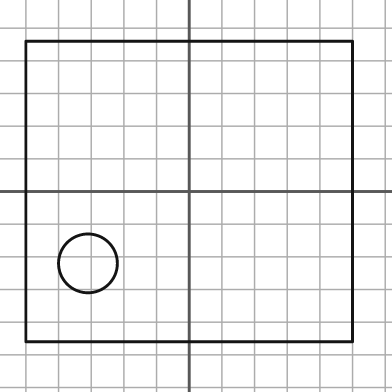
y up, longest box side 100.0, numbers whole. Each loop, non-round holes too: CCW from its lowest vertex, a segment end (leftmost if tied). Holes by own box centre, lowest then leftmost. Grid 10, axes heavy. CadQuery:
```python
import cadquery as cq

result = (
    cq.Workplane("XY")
    .moveTo(-50.0, -46.0)
    .lineTo(50.0, -46.0)
    .lineTo(50.0, 46.0)
    .lineTo(-50.0, 46.0)
    .close()
    .moveTo(-31.0, -22.0)
    .circle(9.0)
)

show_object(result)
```